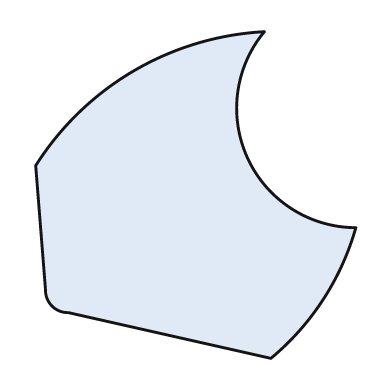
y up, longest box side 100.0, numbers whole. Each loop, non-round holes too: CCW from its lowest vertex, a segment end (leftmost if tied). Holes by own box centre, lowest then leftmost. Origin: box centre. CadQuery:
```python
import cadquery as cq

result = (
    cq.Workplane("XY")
    .moveTo(23.0, -50.0)
    .threePointArc((39.0, -32.0), (49.0, -10.0))
    .threePointArc((16.0, 11.0), (21.0, 50.0))
    .threePointArc((-19.0, 38.0), (-49.0, 9.0))
    .lineTo(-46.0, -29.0)
    .threePointArc((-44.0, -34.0), (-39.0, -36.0))
    .close()
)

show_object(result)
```